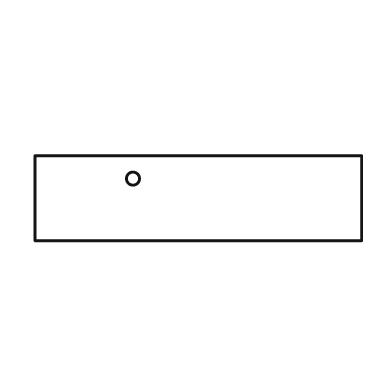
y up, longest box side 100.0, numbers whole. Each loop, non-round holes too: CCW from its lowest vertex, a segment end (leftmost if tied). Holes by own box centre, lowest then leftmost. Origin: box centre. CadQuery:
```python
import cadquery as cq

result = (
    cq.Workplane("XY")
    .moveTo(-50.0, -13.0)
    .lineTo(50.0, -13.0)
    .lineTo(50.0, 13.0)
    .lineTo(-50.0, 13.0)
    .close()
    .moveTo(-20.0, 6.0)
    .circle(2.0)
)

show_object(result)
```